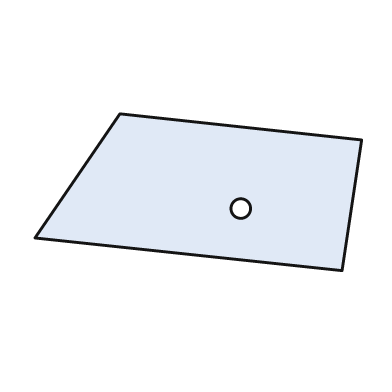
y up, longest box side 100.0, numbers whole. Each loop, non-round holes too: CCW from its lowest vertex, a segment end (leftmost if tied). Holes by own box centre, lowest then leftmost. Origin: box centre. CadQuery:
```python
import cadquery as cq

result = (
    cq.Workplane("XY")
    .moveTo(44.0, -24.0)
    .lineTo(50.0, 16.0)
    .lineTo(-24.0, 24.0)
    .lineTo(-50.0, -14.0)
    .close()
    .moveTo(13.0, -5.0)
    .circle(3.0)
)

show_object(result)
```